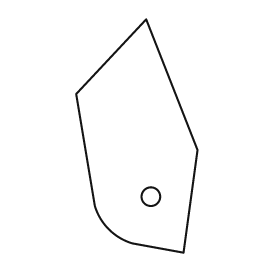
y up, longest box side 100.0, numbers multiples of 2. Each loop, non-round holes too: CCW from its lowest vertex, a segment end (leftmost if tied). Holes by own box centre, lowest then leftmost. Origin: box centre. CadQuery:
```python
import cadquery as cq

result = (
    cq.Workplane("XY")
    .moveTo(20.0, -50.0)
    .lineTo(26.0, -6.0)
    .lineTo(4.0, 50.0)
    .lineTo(-26.0, 18.0)
    .lineTo(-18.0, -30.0)
    .threePointArc((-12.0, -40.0), (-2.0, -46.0))
    .close()
    .moveTo(6.0, -26.0)
    .circle(4.0)
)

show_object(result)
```